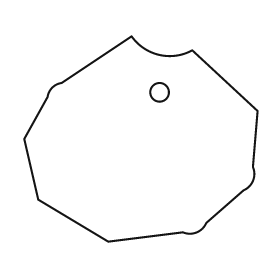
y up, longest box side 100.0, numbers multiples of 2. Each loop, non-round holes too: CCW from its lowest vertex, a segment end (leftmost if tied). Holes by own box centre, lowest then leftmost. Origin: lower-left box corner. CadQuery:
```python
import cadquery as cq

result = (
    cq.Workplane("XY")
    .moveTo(36.0, 0.0)
    .lineTo(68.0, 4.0)
    .threePointArc((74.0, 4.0), (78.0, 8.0))
    .lineTo(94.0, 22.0)
    .threePointArc((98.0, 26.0), (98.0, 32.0))
    .lineTo(100.0, 56.0)
    .lineTo(72.0, 82.0)
    .threePointArc((58.0, 80.0), (46.0, 88.0))
    .lineTo(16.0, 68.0)
    .threePointArc((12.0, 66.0), (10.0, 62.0))
    .lineTo(0.0, 44.0)
    .lineTo(6.0, 18.0)
    .close()
    .moveTo(58.0, 64.0)
    .circle(4.0)
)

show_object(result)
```